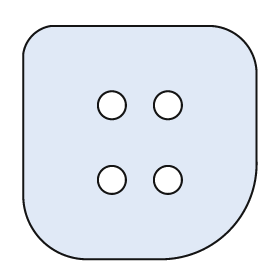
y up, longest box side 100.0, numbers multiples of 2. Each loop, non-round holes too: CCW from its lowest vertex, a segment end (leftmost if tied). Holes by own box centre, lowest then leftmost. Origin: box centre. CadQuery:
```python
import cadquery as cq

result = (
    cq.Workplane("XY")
    .moveTo(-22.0, -50.0)
    .lineTo(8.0, -50.0)
    .threePointArc((38.0, -38.0), (50.0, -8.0))
    .lineTo(50.0, 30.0)
    .threePointArc((44.0, 44.0), (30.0, 50.0))
    .lineTo(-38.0, 50.0)
    .threePointArc((-46.0, 46.0), (-50.0, 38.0))
    .lineTo(-50.0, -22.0)
    .threePointArc((-42.0, -42.0), (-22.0, -50.0))
    .close()
    .moveTo(-12.0, -16.0)
    .circle(6.0)
    .moveTo(12.0, -16.0)
    .circle(6.0)
    .moveTo(-12.0, 16.0)
    .circle(6.0)
    .moveTo(12.0, 16.0)
    .circle(6.0)
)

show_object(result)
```